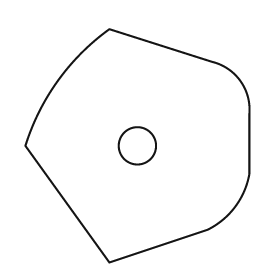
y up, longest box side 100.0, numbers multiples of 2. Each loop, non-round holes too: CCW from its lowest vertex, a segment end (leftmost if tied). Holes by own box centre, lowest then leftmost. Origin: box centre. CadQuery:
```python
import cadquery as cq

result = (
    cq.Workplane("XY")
    .moveTo(-12.0, -50.0)
    .lineTo(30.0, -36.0)
    .threePointArc((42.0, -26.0), (48.0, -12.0))
    .lineTo(48.0, 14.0)
    .threePointArc((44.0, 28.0), (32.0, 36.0))
    .lineTo(-12.0, 50.0)
    .threePointArc((-34.0, 28.0), (-48.0, 0.0))
    .close()
    .moveTo(0.0, 0.0)
    .circle(8.0)
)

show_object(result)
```